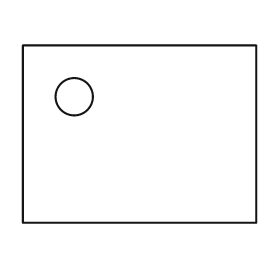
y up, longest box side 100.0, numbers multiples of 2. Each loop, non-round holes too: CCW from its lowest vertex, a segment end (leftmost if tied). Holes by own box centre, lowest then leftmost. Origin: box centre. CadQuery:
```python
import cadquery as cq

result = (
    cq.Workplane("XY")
    .moveTo(-50.0, -38.0)
    .lineTo(50.0, -38.0)
    .lineTo(50.0, 38.0)
    .lineTo(-50.0, 38.0)
    .close()
    .moveTo(-28.0, 16.0)
    .circle(8.0)
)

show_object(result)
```